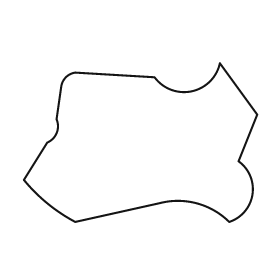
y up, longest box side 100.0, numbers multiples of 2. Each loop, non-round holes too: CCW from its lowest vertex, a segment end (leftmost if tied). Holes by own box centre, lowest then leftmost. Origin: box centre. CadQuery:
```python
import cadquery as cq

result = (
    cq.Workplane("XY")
    .moveTo(-28.0, -34.0)
    .lineTo(8.0, -26.0)
    .threePointArc((24.0, -26.0), (38.0, -34.0))
    .threePointArc((48.0, -22.0), (42.0, -8.0))
    .lineTo(50.0, 12.0)
    .lineTo(34.0, 34.0)
    .threePointArc((22.0, 22.0), (6.0, 28.0))
    .lineTo(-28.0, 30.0)
    .threePointArc((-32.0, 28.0), (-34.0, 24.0))
    .lineTo(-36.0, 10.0)
    .threePointArc((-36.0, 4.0), (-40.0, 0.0))
    .lineTo(-50.0, -16.0)
    .threePointArc((-40.0, -26.0), (-28.0, -34.0))
    .close()
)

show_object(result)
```